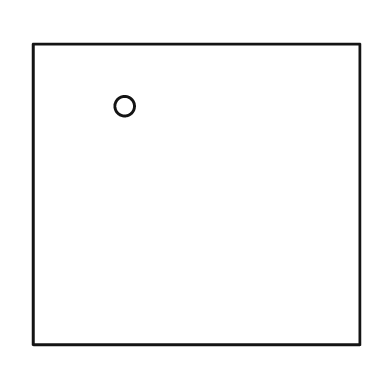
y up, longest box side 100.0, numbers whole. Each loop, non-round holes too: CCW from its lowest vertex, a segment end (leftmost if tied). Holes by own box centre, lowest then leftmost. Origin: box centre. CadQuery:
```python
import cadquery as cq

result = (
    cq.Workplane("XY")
    .moveTo(-50.0, -46.0)
    .lineTo(50.0, -46.0)
    .lineTo(50.0, 46.0)
    .lineTo(-50.0, 46.0)
    .close()
    .moveTo(-22.0, 27.0)
    .circle(3.0)
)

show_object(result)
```